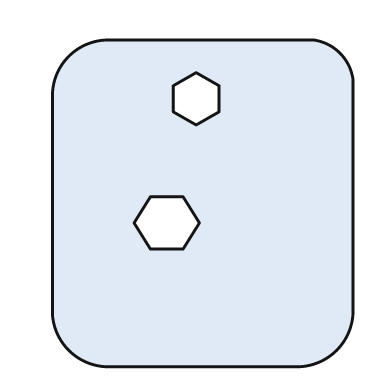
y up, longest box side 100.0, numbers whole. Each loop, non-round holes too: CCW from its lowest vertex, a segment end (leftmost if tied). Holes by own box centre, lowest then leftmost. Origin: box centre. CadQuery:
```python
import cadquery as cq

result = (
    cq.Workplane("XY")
    .moveTo(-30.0, -50.0)
    .lineTo(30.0, -50.0)
    .threePointArc((41.0, -45.0), (46.0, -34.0))
    .lineTo(46.0, 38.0)
    .threePointArc((42.0, 46.0), (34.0, 50.0))
    .lineTo(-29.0, 50.0)
    .threePointArc((-41.0, 45.0), (-46.0, 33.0))
    .lineTo(-46.0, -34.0)
    .threePointArc((-41.0, -45.0), (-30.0, -50.0))
    .close()
    .moveTo(-16.0, -14.0)
    .lineTo(-6.0, -14.0)
    .lineTo(-1.0, -6.0)
    .lineTo(-6.0, 2.0)
    .lineTo(-16.0, 2.0)
    .lineTo(-21.0, -6.0)
    .close()
    .moveTo(-2.0, 24.0)
    .lineTo(5.0, 28.0)
    .lineTo(5.0, 36.0)
    .lineTo(-2.0, 40.0)
    .lineTo(-9.0, 36.0)
    .lineTo(-9.0, 28.0)
    .close()
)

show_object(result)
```